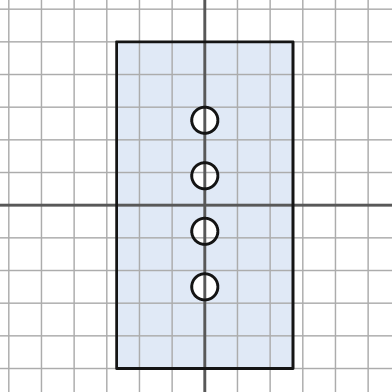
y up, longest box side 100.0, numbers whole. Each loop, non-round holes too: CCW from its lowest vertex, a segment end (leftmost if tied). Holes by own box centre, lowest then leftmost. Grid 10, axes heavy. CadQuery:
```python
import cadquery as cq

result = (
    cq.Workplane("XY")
    .moveTo(-27.0, -50.0)
    .lineTo(27.0, -50.0)
    .lineTo(27.0, 50.0)
    .lineTo(-27.0, 50.0)
    .close()
    .moveTo(0.0, -25.0)
    .circle(4.0)
    .moveTo(0.0, -8.0)
    .circle(4.0)
    .moveTo(0.0, 9.0)
    .circle(4.0)
    .moveTo(0.0, 26.0)
    .circle(4.0)
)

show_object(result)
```